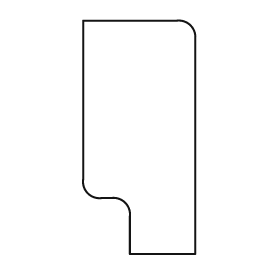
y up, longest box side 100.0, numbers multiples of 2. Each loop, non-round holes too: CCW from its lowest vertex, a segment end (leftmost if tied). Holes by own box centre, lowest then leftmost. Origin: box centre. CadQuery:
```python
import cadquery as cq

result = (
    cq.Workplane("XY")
    .moveTo(-4.0, -50.0)
    .lineTo(24.0, -50.0)
    .lineTo(24.0, 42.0)
    .threePointArc((22.0, 48.0), (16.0, 50.0))
    .lineTo(-24.0, 50.0)
    .lineTo(-24.0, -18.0)
    .threePointArc((-22.0, -24.0), (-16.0, -26.0))
    .lineTo(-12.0, -26.0)
    .threePointArc((-6.0, -28.0), (-4.0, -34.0))
    .close()
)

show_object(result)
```